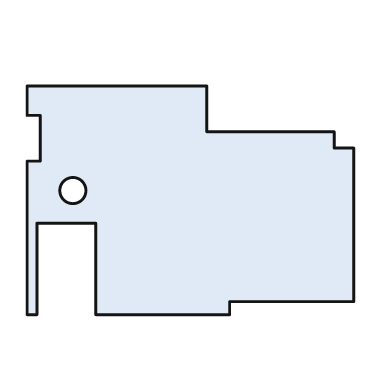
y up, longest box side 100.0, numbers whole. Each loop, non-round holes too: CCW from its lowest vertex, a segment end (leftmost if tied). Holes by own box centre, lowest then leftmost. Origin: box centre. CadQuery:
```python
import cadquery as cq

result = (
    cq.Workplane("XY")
    .moveTo(-50.0, -35.0)
    .lineTo(-47.0, -35.0)
    .lineTo(-47.0, -7.0)
    .lineTo(-29.0, -7.0)
    .lineTo(-29.0, -35.0)
    .lineTo(12.0, -35.0)
    .lineTo(12.0, -31.0)
    .lineTo(50.0, -31.0)
    .lineTo(50.0, 16.0)
    .lineTo(44.0, 16.0)
    .lineTo(44.0, 21.0)
    .lineTo(5.0, 21.0)
    .lineTo(5.0, 35.0)
    .lineTo(-50.0, 35.0)
    .lineTo(-50.0, 26.0)
    .lineTo(-46.0, 26.0)
    .lineTo(-46.0, 12.0)
    .lineTo(-50.0, 12.0)
    .close()
    .moveTo(-36.0, 3.0)
    .circle(4.0)
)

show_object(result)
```